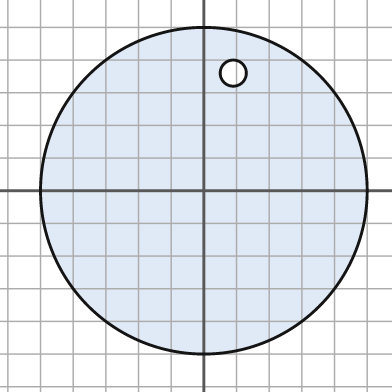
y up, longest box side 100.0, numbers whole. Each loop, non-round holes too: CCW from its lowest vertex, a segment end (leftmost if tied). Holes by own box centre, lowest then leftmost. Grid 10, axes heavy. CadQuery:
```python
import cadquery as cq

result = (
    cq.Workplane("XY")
    .moveTo(0.0, 0.0)
    .circle(50.0)
    .moveTo(9.0, 36.0)
    .circle(4.0)
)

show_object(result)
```